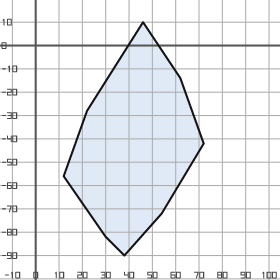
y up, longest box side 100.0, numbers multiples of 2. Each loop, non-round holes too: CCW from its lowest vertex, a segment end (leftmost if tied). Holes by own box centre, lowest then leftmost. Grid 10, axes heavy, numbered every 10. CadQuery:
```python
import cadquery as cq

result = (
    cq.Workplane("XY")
    .moveTo(38.0, -90.0)
    .lineTo(54.0, -72.0)
    .lineTo(72.0, -42.0)
    .lineTo(62.0, -14.0)
    .lineTo(46.0, 10.0)
    .lineTo(22.0, -28.0)
    .lineTo(12.0, -56.0)
    .lineTo(30.0, -82.0)
    .close()
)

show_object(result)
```